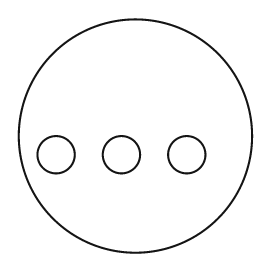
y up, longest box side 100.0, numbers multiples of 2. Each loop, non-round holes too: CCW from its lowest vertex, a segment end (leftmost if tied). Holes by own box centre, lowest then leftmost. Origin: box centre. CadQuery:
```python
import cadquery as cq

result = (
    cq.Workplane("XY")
    .moveTo(0.0, 0.0)
    .circle(50.0)
    .moveTo(-34.0, -8.0)
    .circle(8.0)
    .moveTo(-6.0, -8.0)
    .circle(8.0)
    .moveTo(22.0, -8.0)
    .circle(8.0)
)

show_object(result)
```